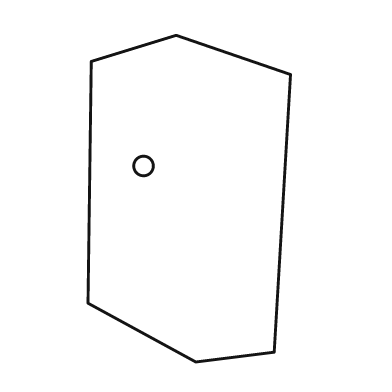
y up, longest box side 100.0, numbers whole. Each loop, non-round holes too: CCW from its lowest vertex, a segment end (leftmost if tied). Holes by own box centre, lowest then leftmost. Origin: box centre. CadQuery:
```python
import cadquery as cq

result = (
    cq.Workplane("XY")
    .moveTo(2.0, -50.0)
    .lineTo(26.0, -47.0)
    .lineTo(31.0, 38.0)
    .lineTo(-4.0, 50.0)
    .lineTo(-30.0, 42.0)
    .lineTo(-31.0, -32.0)
    .close()
    .moveTo(-14.0, 10.0)
    .circle(3.0)
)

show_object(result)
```